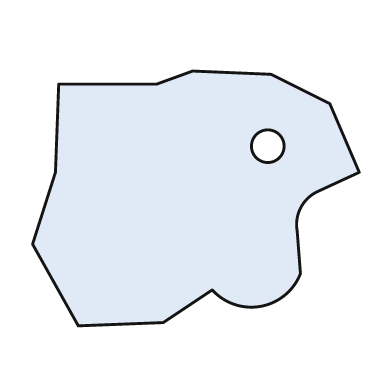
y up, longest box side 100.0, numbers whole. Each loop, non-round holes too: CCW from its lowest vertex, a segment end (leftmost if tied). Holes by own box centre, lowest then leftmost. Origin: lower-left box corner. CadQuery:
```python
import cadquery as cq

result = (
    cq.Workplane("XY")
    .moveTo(14.0, 0.0)
    .lineTo(40.0, 1.0)
    .lineTo(55.0, 11.0)
    .threePointArc((70.0, 6.0), (82.0, 16.0))
    .lineTo(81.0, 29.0)
    .threePointArc((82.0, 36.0), (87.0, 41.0))
    .lineTo(100.0, 47.0)
    .lineTo(91.0, 68.0)
    .lineTo(73.0, 77.0)
    .lineTo(49.0, 78.0)
    .lineTo(38.0, 74.0)
    .lineTo(8.0, 74.0)
    .lineTo(7.0, 47.0)
    .lineTo(0.0, 25.0)
    .close()
    .moveTo(72.0, 55.0)
    .circle(5.0)
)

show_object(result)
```